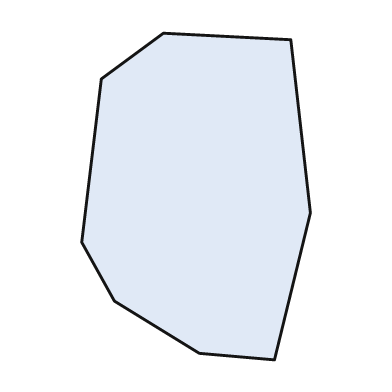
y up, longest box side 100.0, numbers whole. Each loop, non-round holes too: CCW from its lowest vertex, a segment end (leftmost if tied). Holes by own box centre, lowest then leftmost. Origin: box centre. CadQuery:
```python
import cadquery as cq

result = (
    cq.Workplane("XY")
    .moveTo(24.0, -50.0)
    .lineTo(35.0, -5.0)
    .lineTo(29.0, 48.0)
    .lineTo(-10.0, 50.0)
    .lineTo(-29.0, 36.0)
    .lineTo(-35.0, -14.0)
    .lineTo(-25.0, -32.0)
    .lineTo(1.0, -48.0)
    .close()
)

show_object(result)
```